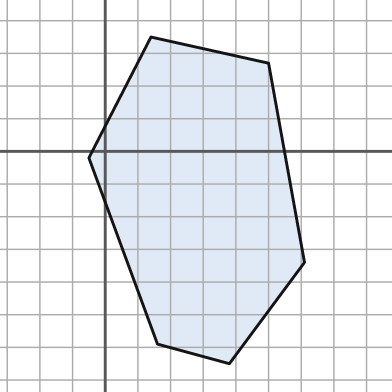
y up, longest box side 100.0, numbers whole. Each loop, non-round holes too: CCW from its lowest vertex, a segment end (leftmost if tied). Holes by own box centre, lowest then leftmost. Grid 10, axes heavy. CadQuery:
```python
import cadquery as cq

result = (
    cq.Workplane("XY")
    .moveTo(38.0, -65.0)
    .lineTo(61.0, -34.0)
    .lineTo(50.0, 27.0)
    .lineTo(14.0, 35.0)
    .lineTo(-5.0, -2.0)
    .lineTo(16.0, -59.0)
    .close()
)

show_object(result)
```